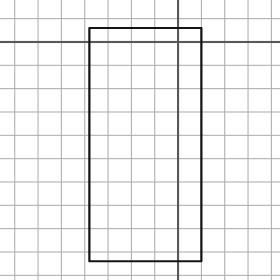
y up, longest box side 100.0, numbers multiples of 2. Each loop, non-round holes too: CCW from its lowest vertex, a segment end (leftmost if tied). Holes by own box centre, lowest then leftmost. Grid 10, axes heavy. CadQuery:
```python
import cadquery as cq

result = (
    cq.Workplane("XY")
    .moveTo(-38.0, -94.0)
    .lineTo(10.0, -94.0)
    .lineTo(10.0, 6.0)
    .lineTo(-38.0, 6.0)
    .close()
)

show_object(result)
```